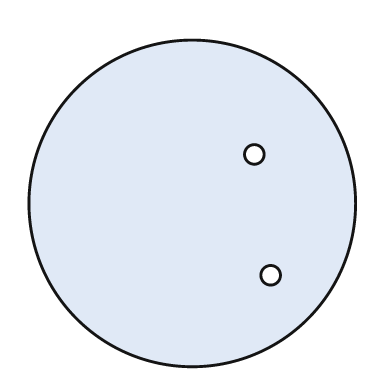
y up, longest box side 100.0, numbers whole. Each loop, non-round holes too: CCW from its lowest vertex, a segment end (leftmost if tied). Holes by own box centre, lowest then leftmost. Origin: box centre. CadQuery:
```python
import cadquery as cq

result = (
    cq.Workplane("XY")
    .moveTo(0.0, 0.0)
    .circle(50.0)
    .moveTo(24.0, -22.0)
    .circle(3.0)
    .moveTo(19.0, 15.0)
    .circle(3.0)
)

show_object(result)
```